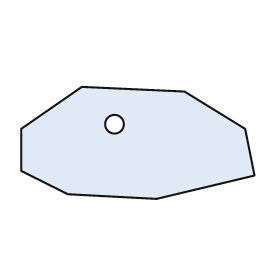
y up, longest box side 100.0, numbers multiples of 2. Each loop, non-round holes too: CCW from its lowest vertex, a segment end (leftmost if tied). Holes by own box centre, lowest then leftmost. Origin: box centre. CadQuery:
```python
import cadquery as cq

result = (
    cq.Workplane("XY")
    .moveTo(8.0, -24.0)
    .lineTo(50.0, -14.0)
    .lineTo(46.0, 6.0)
    .lineTo(20.0, 22.0)
    .lineTo(-24.0, 24.0)
    .lineTo(-50.0, 6.0)
    .lineTo(-50.0, -12.0)
    .lineTo(-30.0, -22.0)
    .close()
    .moveTo(-10.0, 8.0)
    .circle(4.0)
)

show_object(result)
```